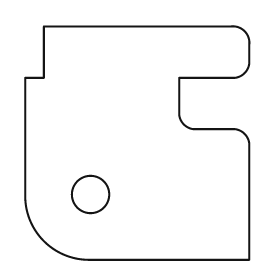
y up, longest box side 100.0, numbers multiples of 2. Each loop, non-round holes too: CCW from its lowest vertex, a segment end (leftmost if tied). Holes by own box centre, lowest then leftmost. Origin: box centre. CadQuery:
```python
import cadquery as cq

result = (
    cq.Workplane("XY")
    .moveTo(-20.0, -50.0)
    .lineTo(48.0, -50.0)
    .lineTo(48.0, 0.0)
    .threePointArc((46.0, 4.0), (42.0, 6.0))
    .lineTo(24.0, 6.0)
    .threePointArc((20.0, 8.0), (18.0, 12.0))
    .lineTo(18.0, 28.0)
    .lineTo(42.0, 28.0)
    .threePointArc((46.0, 30.0), (48.0, 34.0))
    .lineTo(48.0, 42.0)
    .threePointArc((46.0, 48.0), (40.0, 50.0))
    .lineTo(-40.0, 50.0)
    .lineTo(-40.0, 28.0)
    .lineTo(-48.0, 28.0)
    .lineTo(-48.0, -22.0)
    .threePointArc((-40.0, -42.0), (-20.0, -50.0))
    .close()
    .moveTo(-20.0, -22.0)
    .circle(8.0)
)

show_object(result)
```